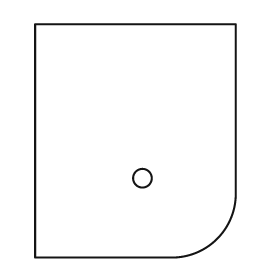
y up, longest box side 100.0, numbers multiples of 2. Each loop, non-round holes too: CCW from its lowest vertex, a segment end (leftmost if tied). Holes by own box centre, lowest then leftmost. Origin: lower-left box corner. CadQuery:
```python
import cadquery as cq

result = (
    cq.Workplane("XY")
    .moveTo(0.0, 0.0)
    .lineTo(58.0, 0.0)
    .threePointArc((78.0, 8.0), (86.0, 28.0))
    .lineTo(86.0, 100.0)
    .lineTo(0.0, 100.0)
    .close()
    .moveTo(46.0, 34.0)
    .circle(4.0)
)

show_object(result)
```